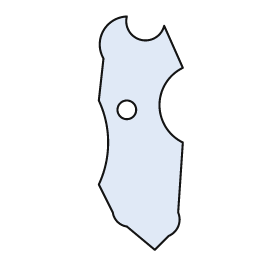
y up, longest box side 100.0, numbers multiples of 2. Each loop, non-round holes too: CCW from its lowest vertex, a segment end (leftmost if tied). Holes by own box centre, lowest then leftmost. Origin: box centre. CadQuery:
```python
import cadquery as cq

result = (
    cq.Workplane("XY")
    .moveTo(6.0, -50.0)
    .lineTo(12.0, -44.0)
    .threePointArc((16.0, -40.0), (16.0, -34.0))
    .lineTo(18.0, -4.0)
    .threePointArc((8.0, 12.0), (18.0, 28.0))
    .lineTo(10.0, 46.0)
    .threePointArc((0.0, 40.0), (-6.0, 50.0))
    .threePointArc((-16.0, 44.0), (-16.0, 32.0))
    .lineTo(-18.0, 14.0)
    .threePointArc((-14.0, -4.0), (-18.0, -22.0))
    .lineTo(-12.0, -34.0)
    .threePointArc((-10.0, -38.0), (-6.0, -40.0))
    .close()
    .moveTo(-6.0, 10.0)
    .circle(4.0)
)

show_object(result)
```